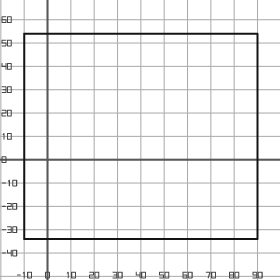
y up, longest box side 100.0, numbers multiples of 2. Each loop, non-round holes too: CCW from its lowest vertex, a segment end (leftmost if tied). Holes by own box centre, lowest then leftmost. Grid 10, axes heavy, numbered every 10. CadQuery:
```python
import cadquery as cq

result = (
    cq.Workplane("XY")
    .moveTo(-10.0, -34.0)
    .lineTo(90.0, -34.0)
    .lineTo(90.0, 54.0)
    .lineTo(-10.0, 54.0)
    .close()
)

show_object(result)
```